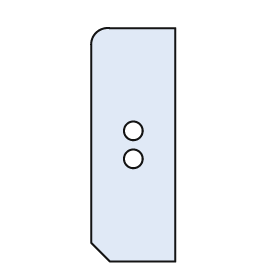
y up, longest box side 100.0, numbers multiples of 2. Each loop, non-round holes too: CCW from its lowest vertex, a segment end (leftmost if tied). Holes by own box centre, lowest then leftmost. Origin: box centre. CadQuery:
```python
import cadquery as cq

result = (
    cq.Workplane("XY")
    .moveTo(-10.0, -50.0)
    .lineTo(18.0, -50.0)
    .lineTo(18.0, 50.0)
    .lineTo(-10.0, 50.0)
    .threePointArc((-16.0, 48.0), (-18.0, 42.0))
    .lineTo(-18.0, -42.0)
    .close()
    .moveTo(0.0, -6.0)
    .circle(4.0)
    .moveTo(0.0, 6.0)
    .circle(4.0)
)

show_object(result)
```